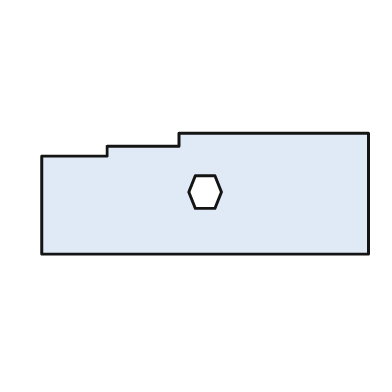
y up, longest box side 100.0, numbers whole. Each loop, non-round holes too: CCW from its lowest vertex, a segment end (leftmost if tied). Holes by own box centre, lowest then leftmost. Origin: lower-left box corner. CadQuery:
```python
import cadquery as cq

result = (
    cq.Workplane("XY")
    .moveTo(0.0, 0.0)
    .lineTo(100.0, 0.0)
    .lineTo(100.0, 37.0)
    .lineTo(42.0, 37.0)
    .lineTo(42.0, 33.0)
    .lineTo(20.0, 33.0)
    .lineTo(20.0, 30.0)
    .lineTo(0.0, 30.0)
    .close()
    .moveTo(47.0, 14.0)
    .lineTo(53.0, 14.0)
    .lineTo(55.0, 19.0)
    .lineTo(53.0, 24.0)
    .lineTo(47.0, 24.0)
    .lineTo(45.0, 19.0)
    .close()
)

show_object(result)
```